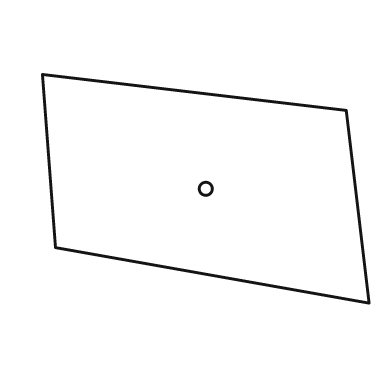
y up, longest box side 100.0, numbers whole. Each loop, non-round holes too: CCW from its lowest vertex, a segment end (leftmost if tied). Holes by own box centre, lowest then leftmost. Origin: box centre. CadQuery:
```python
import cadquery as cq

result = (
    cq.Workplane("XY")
    .moveTo(50.0, -35.0)
    .lineTo(43.0, 24.0)
    .lineTo(-50.0, 35.0)
    .lineTo(-46.0, -18.0)
    .close()
    .moveTo(0.0, 0.0)
    .circle(2.0)
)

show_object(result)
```